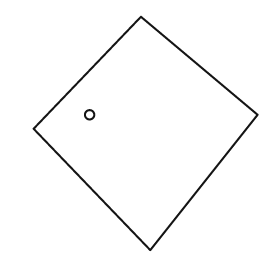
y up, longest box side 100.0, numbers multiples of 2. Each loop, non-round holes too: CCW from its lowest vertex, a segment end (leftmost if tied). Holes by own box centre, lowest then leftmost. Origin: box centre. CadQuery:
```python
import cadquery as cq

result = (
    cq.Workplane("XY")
    .moveTo(2.0, -50.0)
    .lineTo(48.0, 8.0)
    .lineTo(-2.0, 50.0)
    .lineTo(-48.0, 2.0)
    .close()
    .moveTo(-24.0, 8.0)
    .circle(2.0)
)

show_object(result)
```